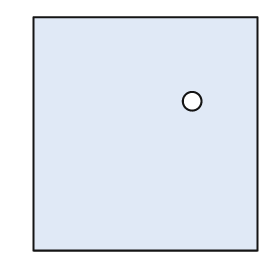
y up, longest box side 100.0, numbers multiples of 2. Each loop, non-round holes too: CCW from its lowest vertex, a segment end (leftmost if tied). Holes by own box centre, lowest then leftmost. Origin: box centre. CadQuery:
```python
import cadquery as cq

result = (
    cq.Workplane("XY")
    .moveTo(-48.0, -50.0)
    .lineTo(48.0, -50.0)
    .lineTo(48.0, 50.0)
    .lineTo(-48.0, 50.0)
    .close()
    .moveTo(20.0, 14.0)
    .circle(4.0)
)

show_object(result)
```